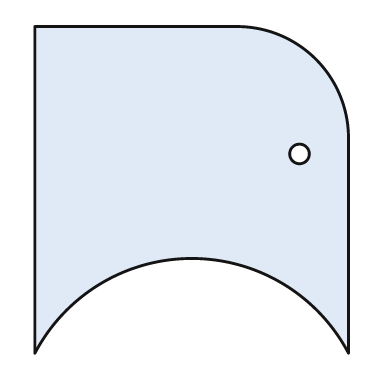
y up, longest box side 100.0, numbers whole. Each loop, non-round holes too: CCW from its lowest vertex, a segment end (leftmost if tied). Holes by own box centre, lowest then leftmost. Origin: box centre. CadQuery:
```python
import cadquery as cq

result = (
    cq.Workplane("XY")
    .moveTo(-48.0, -50.0)
    .threePointArc((0.0, -21.0), (48.0, -50.0))
    .lineTo(48.0, 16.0)
    .threePointArc((38.0, 40.0), (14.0, 50.0))
    .lineTo(-48.0, 50.0)
    .close()
    .moveTo(33.0, 11.0)
    .circle(3.0)
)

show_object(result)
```